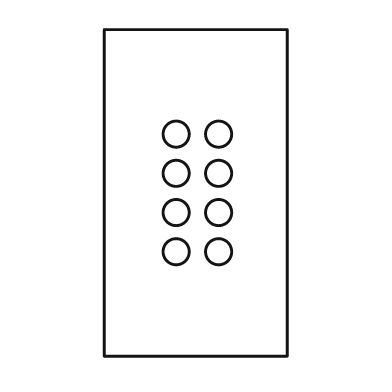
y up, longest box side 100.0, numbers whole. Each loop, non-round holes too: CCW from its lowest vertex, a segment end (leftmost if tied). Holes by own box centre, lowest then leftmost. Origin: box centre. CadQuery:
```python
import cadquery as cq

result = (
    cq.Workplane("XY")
    .moveTo(-28.0, -50.0)
    .lineTo(28.0, -50.0)
    .lineTo(28.0, 50.0)
    .lineTo(-28.0, 50.0)
    .close()
    .moveTo(-6.0, -18.0)
    .circle(4.0)
    .moveTo(7.0, -18.0)
    .circle(4.0)
    .moveTo(-6.0, -6.0)
    .circle(4.0)
    .moveTo(7.0, -6.0)
    .circle(4.0)
    .moveTo(-6.0, 6.0)
    .circle(4.0)
    .moveTo(7.0, 6.0)
    .circle(4.0)
    .moveTo(-6.0, 18.0)
    .circle(4.0)
    .moveTo(7.0, 18.0)
    .circle(4.0)
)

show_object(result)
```